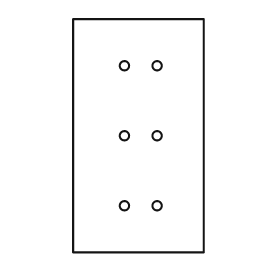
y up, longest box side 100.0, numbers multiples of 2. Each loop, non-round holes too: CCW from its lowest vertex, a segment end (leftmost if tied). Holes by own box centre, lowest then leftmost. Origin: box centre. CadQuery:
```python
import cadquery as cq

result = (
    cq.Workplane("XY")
    .moveTo(-28.0, -50.0)
    .lineTo(28.0, -50.0)
    .lineTo(28.0, 50.0)
    .lineTo(-28.0, 50.0)
    .close()
    .moveTo(-6.0, -30.0)
    .circle(2.0)
    .moveTo(8.0, -30.0)
    .circle(2.0)
    .moveTo(-6.0, 0.0)
    .circle(2.0)
    .moveTo(8.0, 0.0)
    .circle(2.0)
    .moveTo(-6.0, 30.0)
    .circle(2.0)
    .moveTo(8.0, 30.0)
    .circle(2.0)
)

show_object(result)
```